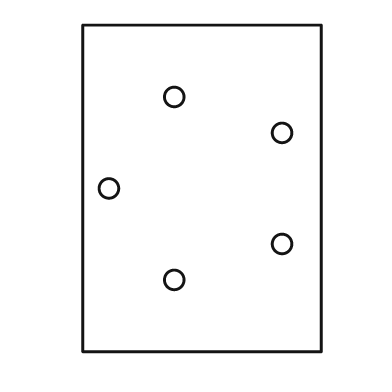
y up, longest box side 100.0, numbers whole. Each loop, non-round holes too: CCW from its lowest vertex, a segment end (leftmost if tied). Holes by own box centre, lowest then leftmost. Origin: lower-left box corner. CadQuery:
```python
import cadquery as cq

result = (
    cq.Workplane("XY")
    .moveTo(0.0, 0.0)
    .lineTo(73.0, 0.0)
    .lineTo(73.0, 100.0)
    .lineTo(0.0, 100.0)
    .close()
    .moveTo(28.0, 22.0)
    .circle(3.0)
    .moveTo(61.0, 33.0)
    .circle(3.0)
    .moveTo(8.0, 50.0)
    .circle(3.0)
    .moveTo(61.0, 67.0)
    .circle(3.0)
    .moveTo(28.0, 78.0)
    .circle(3.0)
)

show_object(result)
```